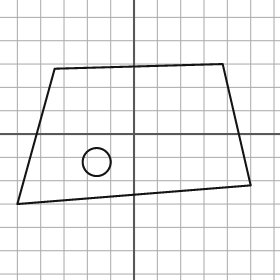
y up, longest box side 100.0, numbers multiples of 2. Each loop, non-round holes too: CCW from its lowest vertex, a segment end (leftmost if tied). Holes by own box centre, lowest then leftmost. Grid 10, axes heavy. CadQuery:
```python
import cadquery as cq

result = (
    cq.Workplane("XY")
    .moveTo(-50.0, -30.0)
    .lineTo(50.0, -22.0)
    .lineTo(38.0, 30.0)
    .lineTo(-34.0, 28.0)
    .close()
    .moveTo(-16.0, -12.0)
    .circle(6.0)
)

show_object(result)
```